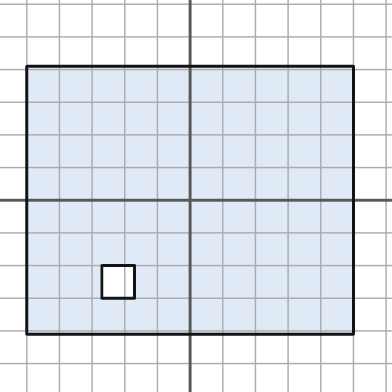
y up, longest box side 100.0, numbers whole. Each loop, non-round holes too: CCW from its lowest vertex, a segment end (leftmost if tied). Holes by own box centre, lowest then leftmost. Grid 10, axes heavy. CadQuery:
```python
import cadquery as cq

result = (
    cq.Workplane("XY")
    .moveTo(-50.0, -41.0)
    .lineTo(50.0, -41.0)
    .lineTo(50.0, 41.0)
    .lineTo(-50.0, 41.0)
    .close()
    .moveTo(-27.0, -30.0)
    .lineTo(-17.0, -30.0)
    .lineTo(-17.0, -20.0)
    .lineTo(-27.0, -20.0)
    .close()
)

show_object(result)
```